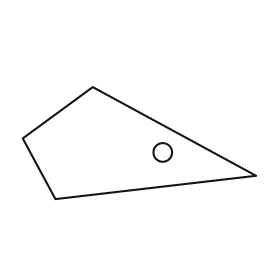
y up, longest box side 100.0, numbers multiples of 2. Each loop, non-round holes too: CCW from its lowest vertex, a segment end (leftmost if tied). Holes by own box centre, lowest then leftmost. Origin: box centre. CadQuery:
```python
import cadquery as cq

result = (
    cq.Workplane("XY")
    .moveTo(-36.0, -24.0)
    .lineTo(50.0, -14.0)
    .lineTo(-20.0, 24.0)
    .lineTo(-50.0, 2.0)
    .close()
    .moveTo(10.0, -4.0)
    .circle(4.0)
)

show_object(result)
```